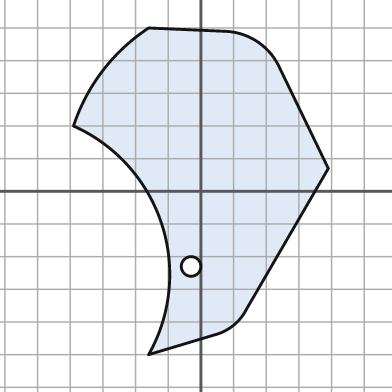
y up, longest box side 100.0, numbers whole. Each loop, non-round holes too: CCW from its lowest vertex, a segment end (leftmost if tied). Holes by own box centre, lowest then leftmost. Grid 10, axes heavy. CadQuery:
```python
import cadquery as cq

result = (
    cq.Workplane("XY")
    .moveTo(-16.0, -50.0)
    .lineTo(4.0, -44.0)
    .threePointArc((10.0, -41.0), (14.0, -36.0))
    .lineTo(39.0, 7.0)
    .lineTo(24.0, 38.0)
    .threePointArc((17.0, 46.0), (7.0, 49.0))
    .lineTo(-16.0, 50.0)
    .threePointArc((-30.0, 37.0), (-39.0, 20.0))
    .threePointArc((-12.0, -10.0), (-16.0, -50.0))
    .close()
    .moveTo(-3.0, -23.0)
    .circle(3.0)
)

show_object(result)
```